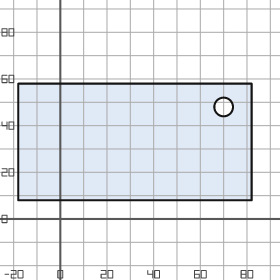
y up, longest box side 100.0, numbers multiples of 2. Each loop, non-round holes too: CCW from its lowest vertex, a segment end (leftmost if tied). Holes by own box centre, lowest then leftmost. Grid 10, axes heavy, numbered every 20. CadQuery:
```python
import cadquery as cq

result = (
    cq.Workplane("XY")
    .moveTo(-18.0, 8.0)
    .lineTo(82.0, 8.0)
    .lineTo(82.0, 58.0)
    .lineTo(-18.0, 58.0)
    .close()
    .moveTo(70.0, 48.0)
    .circle(4.0)
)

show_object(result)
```